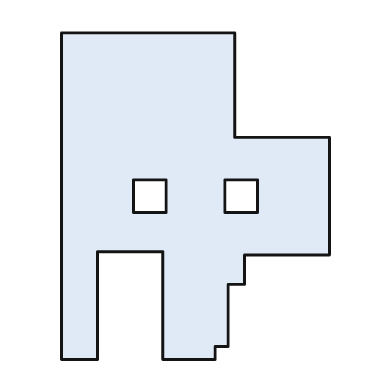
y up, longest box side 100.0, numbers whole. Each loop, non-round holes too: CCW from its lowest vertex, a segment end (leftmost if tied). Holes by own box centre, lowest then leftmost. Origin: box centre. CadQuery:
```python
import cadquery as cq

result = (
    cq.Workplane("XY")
    .moveTo(-41.0, -50.0)
    .lineTo(-30.0, -50.0)
    .lineTo(-30.0, -17.0)
    .lineTo(-10.0, -17.0)
    .lineTo(-10.0, -50.0)
    .lineTo(6.0, -50.0)
    .lineTo(6.0, -46.0)
    .lineTo(10.0, -46.0)
    .lineTo(10.0, -27.0)
    .lineTo(15.0, -27.0)
    .lineTo(15.0, -18.0)
    .lineTo(41.0, -18.0)
    .lineTo(41.0, 18.0)
    .lineTo(12.0, 18.0)
    .lineTo(12.0, 50.0)
    .lineTo(-41.0, 50.0)
    .close()
    .moveTo(-19.0, -5.0)
    .lineTo(-9.0, -5.0)
    .lineTo(-9.0, 5.0)
    .lineTo(-19.0, 5.0)
    .close()
    .moveTo(9.0, -5.0)
    .lineTo(19.0, -5.0)
    .lineTo(19.0, 5.0)
    .lineTo(9.0, 5.0)
    .close()
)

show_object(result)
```